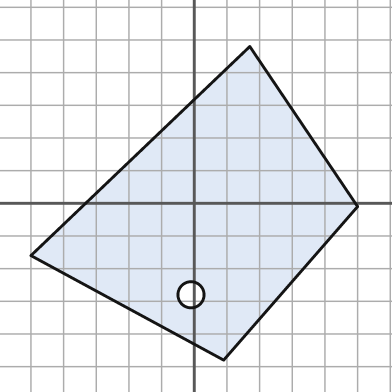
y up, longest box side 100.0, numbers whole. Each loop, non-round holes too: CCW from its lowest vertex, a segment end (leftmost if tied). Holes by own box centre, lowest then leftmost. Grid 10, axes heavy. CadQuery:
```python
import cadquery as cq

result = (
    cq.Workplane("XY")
    .moveTo(9.0, -48.0)
    .lineTo(50.0, -1.0)
    .lineTo(17.0, 48.0)
    .lineTo(-50.0, -16.0)
    .close()
    .moveTo(-1.0, -28.0)
    .circle(4.0)
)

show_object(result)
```